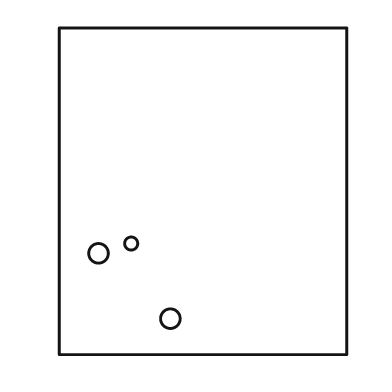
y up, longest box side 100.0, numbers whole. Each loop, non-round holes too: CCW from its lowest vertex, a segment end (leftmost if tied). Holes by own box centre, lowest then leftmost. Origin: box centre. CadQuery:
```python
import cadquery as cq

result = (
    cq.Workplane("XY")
    .moveTo(-44.0, -50.0)
    .lineTo(44.0, -50.0)
    .lineTo(44.0, 50.0)
    .lineTo(-44.0, 50.0)
    .close()
    .moveTo(-10.0, -39.0)
    .circle(3.0)
    .moveTo(-32.0, -19.0)
    .circle(3.0)
    .moveTo(-22.0, -16.0)
    .circle(2.0)
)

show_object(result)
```